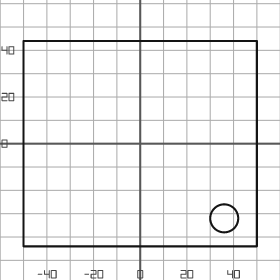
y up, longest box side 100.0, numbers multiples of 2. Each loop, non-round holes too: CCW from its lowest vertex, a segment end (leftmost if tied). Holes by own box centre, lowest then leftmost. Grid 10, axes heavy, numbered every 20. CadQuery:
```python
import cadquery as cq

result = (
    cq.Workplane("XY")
    .moveTo(-50.0, -44.0)
    .lineTo(50.0, -44.0)
    .lineTo(50.0, 44.0)
    .lineTo(-50.0, 44.0)
    .close()
    .moveTo(36.0, -32.0)
    .circle(6.0)
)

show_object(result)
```